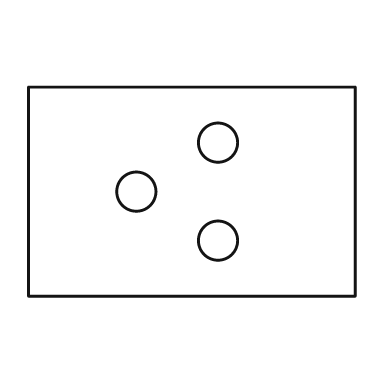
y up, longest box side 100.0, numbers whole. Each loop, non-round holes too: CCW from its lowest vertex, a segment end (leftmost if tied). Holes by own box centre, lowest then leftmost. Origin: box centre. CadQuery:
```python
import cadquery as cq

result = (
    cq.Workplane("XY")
    .moveTo(-50.0, -32.0)
    .lineTo(50.0, -32.0)
    .lineTo(50.0, 32.0)
    .lineTo(-50.0, 32.0)
    .close()
    .moveTo(8.0, -15.0)
    .circle(6.0)
    .moveTo(-17.0, 0.0)
    .circle(6.0)
    .moveTo(8.0, 15.0)
    .circle(6.0)
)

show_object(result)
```